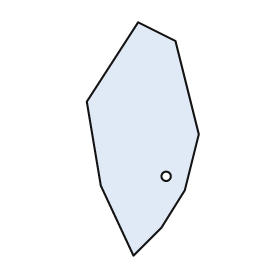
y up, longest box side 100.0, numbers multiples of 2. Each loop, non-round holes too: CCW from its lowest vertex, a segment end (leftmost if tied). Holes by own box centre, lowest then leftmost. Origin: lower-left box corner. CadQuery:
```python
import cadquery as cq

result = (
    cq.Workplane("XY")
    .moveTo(20.0, 0.0)
    .lineTo(32.0, 12.0)
    .lineTo(42.0, 28.0)
    .lineTo(48.0, 52.0)
    .lineTo(38.0, 92.0)
    .lineTo(22.0, 100.0)
    .lineTo(0.0, 66.0)
    .lineTo(6.0, 30.0)
    .close()
    .moveTo(34.0, 34.0)
    .circle(2.0)
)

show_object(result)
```